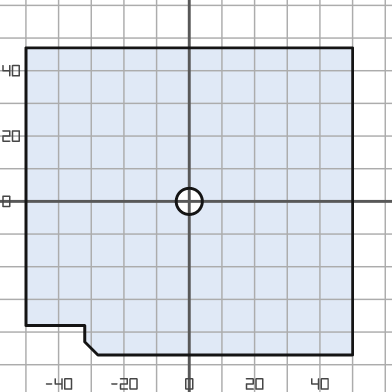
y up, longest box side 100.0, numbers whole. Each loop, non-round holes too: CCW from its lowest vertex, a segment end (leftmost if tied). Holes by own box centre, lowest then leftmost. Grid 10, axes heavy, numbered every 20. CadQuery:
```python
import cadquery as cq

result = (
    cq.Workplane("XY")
    .moveTo(-28.0, -47.0)
    .lineTo(50.0, -47.0)
    .lineTo(50.0, 47.0)
    .lineTo(-50.0, 47.0)
    .lineTo(-50.0, -38.0)
    .lineTo(-32.0, -38.0)
    .lineTo(-32.0, -43.0)
    .close()
    .moveTo(0.0, 0.0)
    .circle(4.0)
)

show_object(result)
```